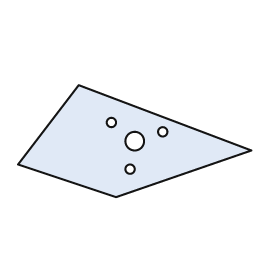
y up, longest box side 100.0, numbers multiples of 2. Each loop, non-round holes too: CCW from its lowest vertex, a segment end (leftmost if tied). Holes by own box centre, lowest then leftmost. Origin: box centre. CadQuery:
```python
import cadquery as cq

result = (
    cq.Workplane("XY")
    .moveTo(-8.0, -24.0)
    .lineTo(50.0, -4.0)
    .lineTo(-24.0, 24.0)
    .lineTo(-50.0, -10.0)
    .close()
    .moveTo(-2.0, -12.0)
    .circle(2.0)
    .moveTo(0.0, 0.0)
    .circle(4.0)
    .moveTo(12.0, 4.0)
    .circle(2.0)
    .moveTo(-10.0, 8.0)
    .circle(2.0)
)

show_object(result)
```